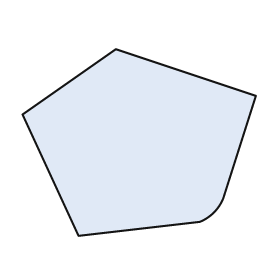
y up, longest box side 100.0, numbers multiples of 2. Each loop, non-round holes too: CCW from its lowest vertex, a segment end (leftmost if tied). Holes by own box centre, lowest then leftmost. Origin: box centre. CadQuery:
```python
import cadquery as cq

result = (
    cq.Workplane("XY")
    .moveTo(-26.0, -40.0)
    .lineTo(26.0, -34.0)
    .threePointArc((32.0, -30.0), (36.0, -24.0))
    .lineTo(50.0, 20.0)
    .lineTo(-10.0, 40.0)
    .lineTo(-50.0, 12.0)
    .close()
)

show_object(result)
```